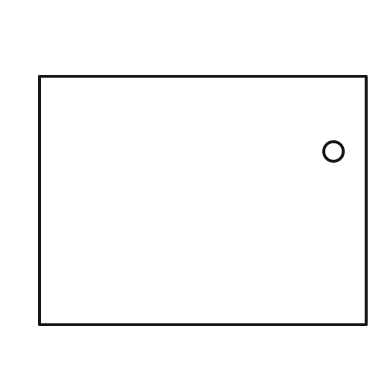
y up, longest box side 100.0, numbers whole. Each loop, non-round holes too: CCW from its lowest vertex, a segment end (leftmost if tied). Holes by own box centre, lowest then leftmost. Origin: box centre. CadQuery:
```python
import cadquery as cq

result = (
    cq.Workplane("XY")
    .moveTo(-50.0, -38.0)
    .lineTo(50.0, -38.0)
    .lineTo(50.0, 38.0)
    .lineTo(-50.0, 38.0)
    .close()
    .moveTo(40.0, 15.0)
    .circle(3.0)
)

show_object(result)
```